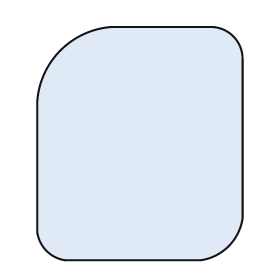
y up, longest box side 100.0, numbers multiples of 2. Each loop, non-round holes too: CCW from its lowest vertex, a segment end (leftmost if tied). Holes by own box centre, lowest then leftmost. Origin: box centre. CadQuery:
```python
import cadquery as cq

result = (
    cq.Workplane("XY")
    .moveTo(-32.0, -50.0)
    .lineTo(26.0, -50.0)
    .threePointArc((38.0, -44.0), (44.0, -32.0))
    .lineTo(44.0, 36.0)
    .threePointArc((40.0, 46.0), (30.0, 50.0))
    .lineTo(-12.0, 50.0)
    .threePointArc((-34.0, 40.0), (-44.0, 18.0))
    .lineTo(-44.0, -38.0)
    .threePointArc((-40.0, -46.0), (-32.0, -50.0))
    .close()
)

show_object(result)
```